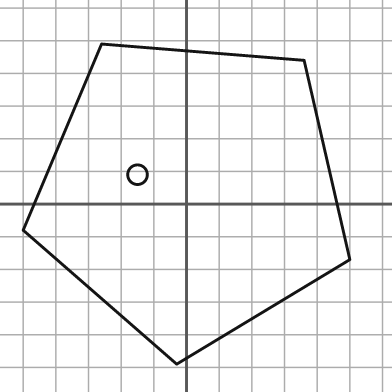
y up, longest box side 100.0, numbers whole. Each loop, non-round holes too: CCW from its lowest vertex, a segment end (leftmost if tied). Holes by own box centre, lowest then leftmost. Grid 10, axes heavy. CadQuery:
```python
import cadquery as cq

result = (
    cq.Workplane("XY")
    .moveTo(-3.0, -49.0)
    .lineTo(50.0, -17.0)
    .lineTo(36.0, 44.0)
    .lineTo(-26.0, 49.0)
    .lineTo(-50.0, -8.0)
    .close()
    .moveTo(-15.0, 9.0)
    .circle(3.0)
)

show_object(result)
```